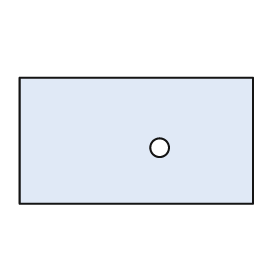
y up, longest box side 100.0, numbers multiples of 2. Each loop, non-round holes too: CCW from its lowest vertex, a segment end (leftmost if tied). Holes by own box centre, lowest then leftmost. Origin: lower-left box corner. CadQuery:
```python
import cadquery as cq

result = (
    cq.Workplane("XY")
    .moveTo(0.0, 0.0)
    .lineTo(100.0, 0.0)
    .lineTo(100.0, 54.0)
    .lineTo(0.0, 54.0)
    .close()
    .moveTo(60.0, 24.0)
    .circle(4.0)
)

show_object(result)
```